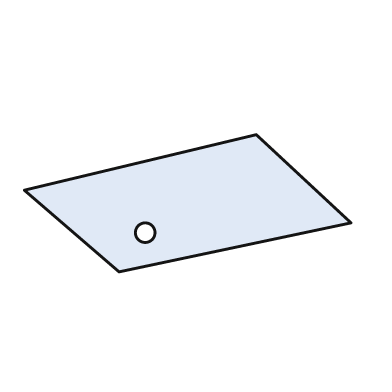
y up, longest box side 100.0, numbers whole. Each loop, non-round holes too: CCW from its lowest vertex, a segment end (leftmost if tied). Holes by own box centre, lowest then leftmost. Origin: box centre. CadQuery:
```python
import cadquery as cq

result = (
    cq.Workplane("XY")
    .moveTo(-21.0, -21.0)
    .lineTo(50.0, -6.0)
    .lineTo(21.0, 21.0)
    .lineTo(-50.0, 4.0)
    .close()
    .moveTo(-13.0, -9.0)
    .circle(3.0)
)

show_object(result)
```